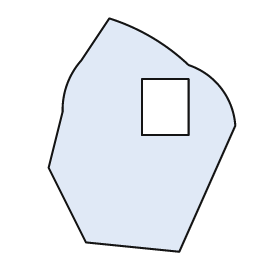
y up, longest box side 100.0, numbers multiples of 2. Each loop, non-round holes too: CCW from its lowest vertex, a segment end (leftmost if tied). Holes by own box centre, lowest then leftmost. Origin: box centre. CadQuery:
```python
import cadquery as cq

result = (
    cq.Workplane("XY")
    .moveTo(16.0, -50.0)
    .lineTo(40.0, 4.0)
    .threePointArc((34.0, 20.0), (20.0, 30.0))
    .threePointArc((4.0, 42.0), (-14.0, 50.0))
    .lineTo(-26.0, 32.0)
    .threePointArc((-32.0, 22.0), (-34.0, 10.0))
    .lineTo(-40.0, -14.0)
    .lineTo(-24.0, -46.0)
    .close()
    .moveTo(0.0, 0.0)
    .lineTo(20.0, 0.0)
    .lineTo(20.0, 24.0)
    .lineTo(0.0, 24.0)
    .close()
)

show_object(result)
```